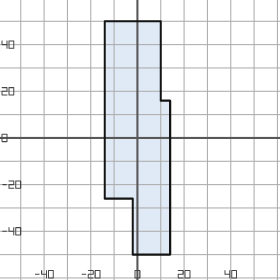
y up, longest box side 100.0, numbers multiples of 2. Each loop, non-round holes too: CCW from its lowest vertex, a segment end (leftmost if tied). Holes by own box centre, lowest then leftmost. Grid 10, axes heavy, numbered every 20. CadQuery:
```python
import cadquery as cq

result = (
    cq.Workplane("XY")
    .moveTo(-2.0, -50.0)
    .lineTo(14.0, -50.0)
    .lineTo(14.0, 16.0)
    .lineTo(10.0, 16.0)
    .lineTo(10.0, 50.0)
    .lineTo(-14.0, 50.0)
    .lineTo(-14.0, -26.0)
    .lineTo(-2.0, -26.0)
    .close()
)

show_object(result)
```